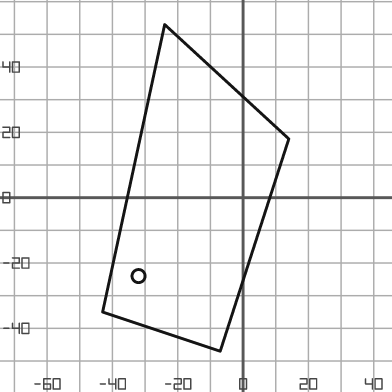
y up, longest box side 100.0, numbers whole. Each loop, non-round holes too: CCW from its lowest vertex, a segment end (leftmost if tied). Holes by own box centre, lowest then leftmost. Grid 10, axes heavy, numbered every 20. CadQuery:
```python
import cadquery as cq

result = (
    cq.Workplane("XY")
    .moveTo(-7.0, -47.0)
    .lineTo(14.0, 18.0)
    .lineTo(-24.0, 53.0)
    .lineTo(-43.0, -35.0)
    .close()
    .moveTo(-32.0, -24.0)
    .circle(2.0)
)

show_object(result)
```